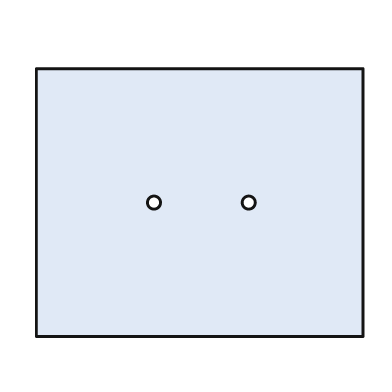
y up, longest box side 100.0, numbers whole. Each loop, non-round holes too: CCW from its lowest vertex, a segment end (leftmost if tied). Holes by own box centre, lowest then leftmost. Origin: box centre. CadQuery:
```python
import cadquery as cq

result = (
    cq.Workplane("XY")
    .moveTo(-50.0, -41.0)
    .lineTo(50.0, -41.0)
    .lineTo(50.0, 41.0)
    .lineTo(-50.0, 41.0)
    .close()
    .moveTo(-14.0, 0.0)
    .circle(2.0)
    .moveTo(15.0, 0.0)
    .circle(2.0)
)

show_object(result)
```